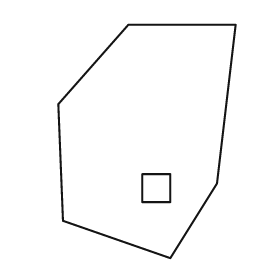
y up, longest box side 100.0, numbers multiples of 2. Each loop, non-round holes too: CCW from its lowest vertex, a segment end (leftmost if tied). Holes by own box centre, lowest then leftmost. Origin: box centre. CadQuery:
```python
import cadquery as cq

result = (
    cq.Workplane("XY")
    .moveTo(10.0, -50.0)
    .lineTo(30.0, -18.0)
    .lineTo(38.0, 50.0)
    .lineTo(-8.0, 50.0)
    .lineTo(-38.0, 16.0)
    .lineTo(-36.0, -34.0)
    .close()
    .moveTo(-2.0, -26.0)
    .lineTo(10.0, -26.0)
    .lineTo(10.0, -14.0)
    .lineTo(-2.0, -14.0)
    .close()
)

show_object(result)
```